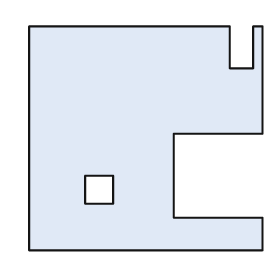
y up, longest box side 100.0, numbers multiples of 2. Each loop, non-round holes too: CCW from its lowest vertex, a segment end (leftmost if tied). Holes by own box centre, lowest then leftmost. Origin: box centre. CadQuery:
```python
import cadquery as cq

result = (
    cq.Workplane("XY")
    .moveTo(-50.0, -48.0)
    .lineTo(50.0, -48.0)
    .lineTo(50.0, -34.0)
    .lineTo(12.0, -34.0)
    .lineTo(12.0, 2.0)
    .lineTo(50.0, 2.0)
    .lineTo(50.0, 48.0)
    .lineTo(46.0, 48.0)
    .lineTo(46.0, 30.0)
    .lineTo(36.0, 30.0)
    .lineTo(36.0, 48.0)
    .lineTo(-50.0, 48.0)
    .close()
    .moveTo(-26.0, -28.0)
    .lineTo(-14.0, -28.0)
    .lineTo(-14.0, -16.0)
    .lineTo(-26.0, -16.0)
    .close()
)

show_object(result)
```